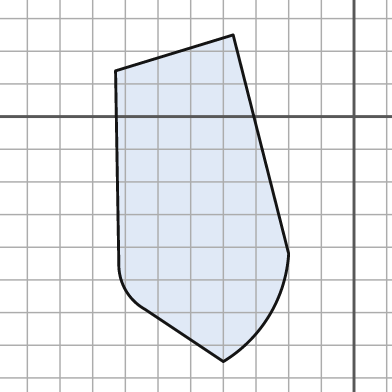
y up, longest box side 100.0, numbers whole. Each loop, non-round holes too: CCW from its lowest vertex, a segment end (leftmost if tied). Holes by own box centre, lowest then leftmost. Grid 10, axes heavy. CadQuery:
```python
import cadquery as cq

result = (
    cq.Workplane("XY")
    .moveTo(-40.0, -75.0)
    .threePointArc((-26.0, -61.0), (-20.0, -42.0))
    .lineTo(-37.0, 25.0)
    .lineTo(-73.0, 14.0)
    .lineTo(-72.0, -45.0)
    .threePointArc((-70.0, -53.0), (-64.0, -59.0))
    .close()
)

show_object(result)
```